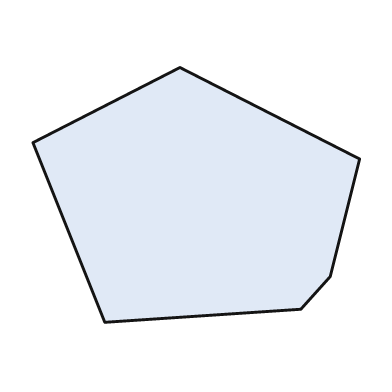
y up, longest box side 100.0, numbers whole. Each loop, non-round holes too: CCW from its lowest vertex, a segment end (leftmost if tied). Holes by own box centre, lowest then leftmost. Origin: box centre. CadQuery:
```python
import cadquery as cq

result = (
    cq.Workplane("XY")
    .moveTo(-28.0, -39.0)
    .lineTo(32.0, -35.0)
    .lineTo(41.0, -25.0)
    .lineTo(50.0, 11.0)
    .lineTo(-5.0, 39.0)
    .lineTo(-50.0, 16.0)
    .close()
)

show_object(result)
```